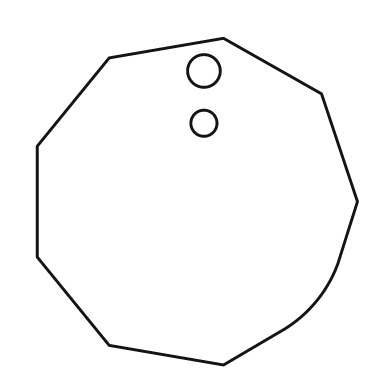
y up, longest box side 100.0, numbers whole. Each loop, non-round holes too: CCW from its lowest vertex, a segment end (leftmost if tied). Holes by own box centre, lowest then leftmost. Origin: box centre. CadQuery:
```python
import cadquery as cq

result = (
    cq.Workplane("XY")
    .moveTo(8.0, -50.0)
    .lineTo(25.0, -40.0)
    .threePointArc((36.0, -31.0), (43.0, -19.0))
    .lineTo(49.0, 0.0)
    .lineTo(38.0, 33.0)
    .lineTo(8.0, 50.0)
    .lineTo(-27.0, 44.0)
    .lineTo(-49.0, 17.0)
    .lineTo(-49.0, -17.0)
    .lineTo(-27.0, -44.0)
    .close()
    .moveTo(2.0, 24.0)
    .circle(4.0)
    .moveTo(2.0, 40.0)
    .circle(5.0)
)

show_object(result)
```